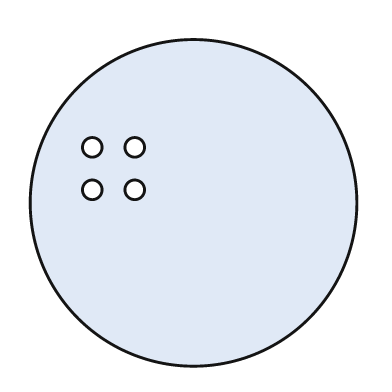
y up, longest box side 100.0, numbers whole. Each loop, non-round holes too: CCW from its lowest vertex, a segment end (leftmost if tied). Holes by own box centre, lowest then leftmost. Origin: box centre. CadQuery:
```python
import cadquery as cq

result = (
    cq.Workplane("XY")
    .moveTo(0.0, 0.0)
    .circle(50.0)
    .moveTo(-31.0, 4.0)
    .circle(3.0)
    .moveTo(-18.0, 4.0)
    .circle(3.0)
    .moveTo(-31.0, 17.0)
    .circle(3.0)
    .moveTo(-18.0, 17.0)
    .circle(3.0)
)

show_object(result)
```